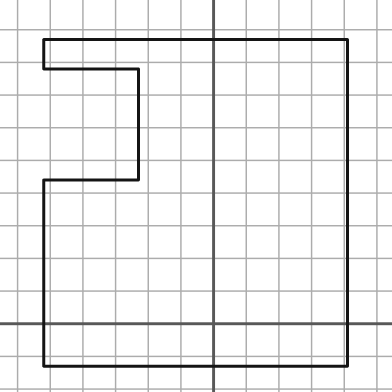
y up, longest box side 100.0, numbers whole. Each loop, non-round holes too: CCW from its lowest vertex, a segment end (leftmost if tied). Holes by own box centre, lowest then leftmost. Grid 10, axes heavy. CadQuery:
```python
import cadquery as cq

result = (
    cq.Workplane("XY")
    .moveTo(-52.0, -13.0)
    .lineTo(41.0, -13.0)
    .lineTo(41.0, 87.0)
    .lineTo(-52.0, 87.0)
    .lineTo(-52.0, 78.0)
    .lineTo(-23.0, 78.0)
    .lineTo(-23.0, 44.0)
    .lineTo(-52.0, 44.0)
    .close()
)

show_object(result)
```